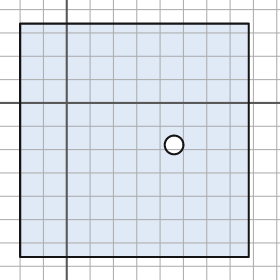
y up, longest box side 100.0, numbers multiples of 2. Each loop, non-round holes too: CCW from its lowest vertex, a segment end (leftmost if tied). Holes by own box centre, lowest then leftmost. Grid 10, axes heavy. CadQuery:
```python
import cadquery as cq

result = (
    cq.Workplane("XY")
    .moveTo(-20.0, -66.0)
    .lineTo(78.0, -66.0)
    .lineTo(78.0, 34.0)
    .lineTo(-20.0, 34.0)
    .close()
    .moveTo(46.0, -18.0)
    .circle(4.0)
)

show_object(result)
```